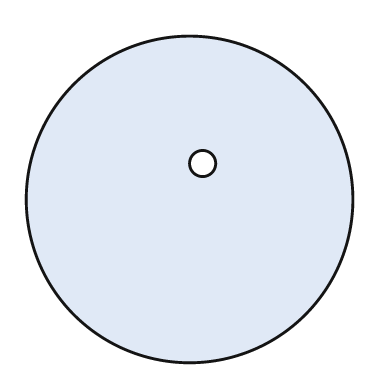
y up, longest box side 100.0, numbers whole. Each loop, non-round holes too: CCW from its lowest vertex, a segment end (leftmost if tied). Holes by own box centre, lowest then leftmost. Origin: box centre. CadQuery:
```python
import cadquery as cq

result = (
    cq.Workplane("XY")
    .moveTo(0.0, 0.0)
    .circle(50.0)
    .moveTo(4.0, 11.0)
    .circle(4.0)
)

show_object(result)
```